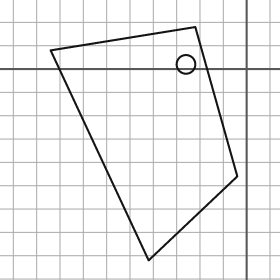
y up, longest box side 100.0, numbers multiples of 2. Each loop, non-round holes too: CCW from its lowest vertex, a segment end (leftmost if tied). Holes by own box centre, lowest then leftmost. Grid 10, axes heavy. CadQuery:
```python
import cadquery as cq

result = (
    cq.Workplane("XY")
    .moveTo(-42.0, -82.0)
    .lineTo(-4.0, -46.0)
    .lineTo(-22.0, 18.0)
    .lineTo(-84.0, 8.0)
    .close()
    .moveTo(-26.0, 2.0)
    .circle(4.0)
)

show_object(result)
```